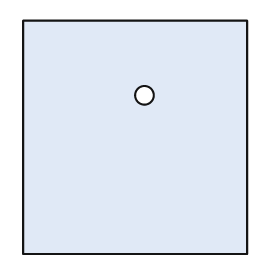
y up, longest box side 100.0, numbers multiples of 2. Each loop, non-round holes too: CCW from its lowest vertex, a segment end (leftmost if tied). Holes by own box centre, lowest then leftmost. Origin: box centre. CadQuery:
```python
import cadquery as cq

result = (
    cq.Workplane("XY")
    .moveTo(-48.0, -50.0)
    .lineTo(48.0, -50.0)
    .lineTo(48.0, 50.0)
    .lineTo(-48.0, 50.0)
    .close()
    .moveTo(4.0, 18.0)
    .circle(4.0)
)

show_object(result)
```